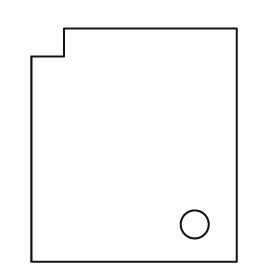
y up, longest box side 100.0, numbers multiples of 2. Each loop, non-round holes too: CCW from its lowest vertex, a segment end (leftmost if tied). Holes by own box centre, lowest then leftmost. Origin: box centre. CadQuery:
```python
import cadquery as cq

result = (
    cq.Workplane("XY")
    .moveTo(-44.0, -50.0)
    .lineTo(44.0, -50.0)
    .lineTo(44.0, 50.0)
    .lineTo(-30.0, 50.0)
    .lineTo(-30.0, 38.0)
    .lineTo(-44.0, 38.0)
    .close()
    .moveTo(26.0, -34.0)
    .circle(6.0)
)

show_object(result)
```